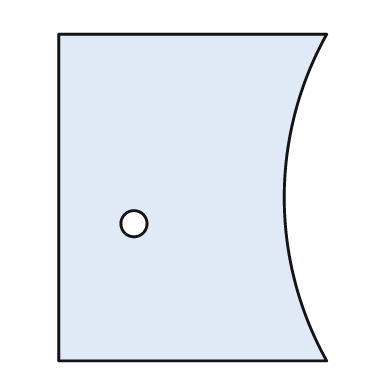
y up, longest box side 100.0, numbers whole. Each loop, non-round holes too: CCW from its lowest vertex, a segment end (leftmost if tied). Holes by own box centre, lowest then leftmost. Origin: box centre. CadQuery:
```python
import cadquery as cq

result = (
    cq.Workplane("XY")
    .moveTo(-41.0, -50.0)
    .lineTo(41.0, -50.0)
    .threePointArc((28.0, 0.0), (41.0, 50.0))
    .lineTo(-41.0, 50.0)
    .close()
    .moveTo(-18.0, -8.0)
    .circle(4.0)
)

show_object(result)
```